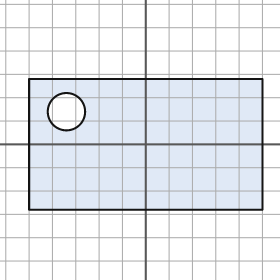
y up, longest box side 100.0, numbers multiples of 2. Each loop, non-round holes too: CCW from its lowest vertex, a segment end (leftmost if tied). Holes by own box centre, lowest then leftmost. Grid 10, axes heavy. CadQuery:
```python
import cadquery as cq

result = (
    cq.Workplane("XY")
    .moveTo(-50.0, -28.0)
    .lineTo(50.0, -28.0)
    .lineTo(50.0, 28.0)
    .lineTo(-50.0, 28.0)
    .close()
    .moveTo(-34.0, 14.0)
    .circle(8.0)
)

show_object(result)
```